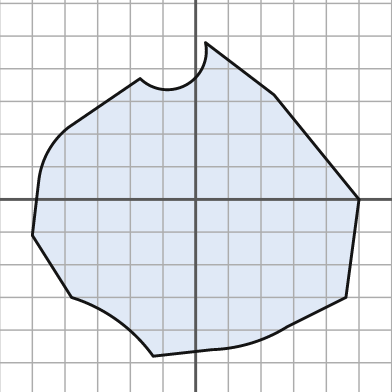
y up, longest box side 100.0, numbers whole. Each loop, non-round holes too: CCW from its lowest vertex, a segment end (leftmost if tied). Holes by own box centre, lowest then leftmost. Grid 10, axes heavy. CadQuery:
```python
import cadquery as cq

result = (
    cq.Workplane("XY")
    .moveTo(-13.0, -48.0)
    .lineTo(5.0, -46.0)
    .threePointArc((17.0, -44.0), (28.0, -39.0))
    .lineTo(46.0, -30.0)
    .lineTo(50.0, 0.0)
    .lineTo(24.0, 32.0)
    .lineTo(3.0, 48.0)
    .threePointArc((-3.0, 35.0), (-17.0, 37.0))
    .lineTo(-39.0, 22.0)
    .threePointArc((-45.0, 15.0), (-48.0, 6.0))
    .lineTo(-50.0, -11.0)
    .lineTo(-38.0, -30.0)
    .threePointArc((-24.0, -37.0), (-13.0, -48.0))
    .close()
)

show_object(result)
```